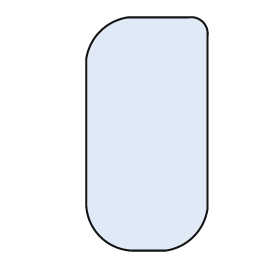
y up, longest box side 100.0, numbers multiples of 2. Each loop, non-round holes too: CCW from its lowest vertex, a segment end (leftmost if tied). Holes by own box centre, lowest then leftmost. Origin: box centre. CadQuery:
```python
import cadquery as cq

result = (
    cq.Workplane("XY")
    .moveTo(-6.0, -50.0)
    .lineTo(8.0, -50.0)
    .threePointArc((20.0, -44.0), (26.0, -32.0))
    .lineTo(26.0, 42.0)
    .threePointArc((24.0, 48.0), (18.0, 50.0))
    .lineTo(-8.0, 50.0)
    .threePointArc((-20.0, 44.0), (-26.0, 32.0))
    .lineTo(-26.0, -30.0)
    .threePointArc((-20.0, -44.0), (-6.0, -50.0))
    .close()
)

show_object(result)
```